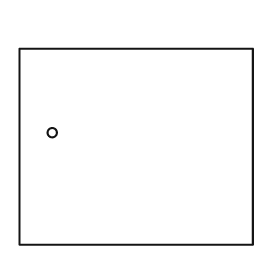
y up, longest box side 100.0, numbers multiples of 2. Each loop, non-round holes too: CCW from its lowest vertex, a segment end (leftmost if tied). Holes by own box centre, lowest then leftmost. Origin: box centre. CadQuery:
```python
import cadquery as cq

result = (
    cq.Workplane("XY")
    .moveTo(-50.0, -42.0)
    .lineTo(50.0, -42.0)
    .lineTo(50.0, 42.0)
    .lineTo(-50.0, 42.0)
    .close()
    .moveTo(-36.0, 6.0)
    .circle(2.0)
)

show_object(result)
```